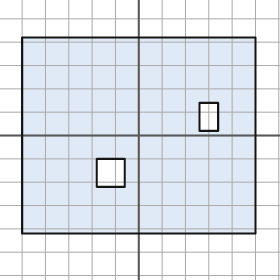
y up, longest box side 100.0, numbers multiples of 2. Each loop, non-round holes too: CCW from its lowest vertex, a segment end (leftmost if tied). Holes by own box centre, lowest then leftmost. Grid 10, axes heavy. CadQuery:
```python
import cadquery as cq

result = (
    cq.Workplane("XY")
    .moveTo(-50.0, -42.0)
    .lineTo(50.0, -42.0)
    .lineTo(50.0, 42.0)
    .lineTo(-50.0, 42.0)
    .close()
    .moveTo(-18.0, -22.0)
    .lineTo(-6.0, -22.0)
    .lineTo(-6.0, -10.0)
    .lineTo(-18.0, -10.0)
    .close()
    .moveTo(26.0, 2.0)
    .lineTo(34.0, 2.0)
    .lineTo(34.0, 14.0)
    .lineTo(26.0, 14.0)
    .close()
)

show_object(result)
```